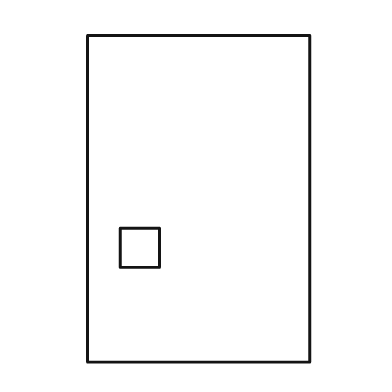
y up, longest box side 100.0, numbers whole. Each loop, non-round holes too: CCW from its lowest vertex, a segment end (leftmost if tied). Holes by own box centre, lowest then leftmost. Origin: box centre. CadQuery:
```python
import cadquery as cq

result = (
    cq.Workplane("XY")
    .moveTo(-34.0, -50.0)
    .lineTo(34.0, -50.0)
    .lineTo(34.0, 50.0)
    .lineTo(-34.0, 50.0)
    .close()
    .moveTo(-24.0, -21.0)
    .lineTo(-12.0, -21.0)
    .lineTo(-12.0, -9.0)
    .lineTo(-24.0, -9.0)
    .close()
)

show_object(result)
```